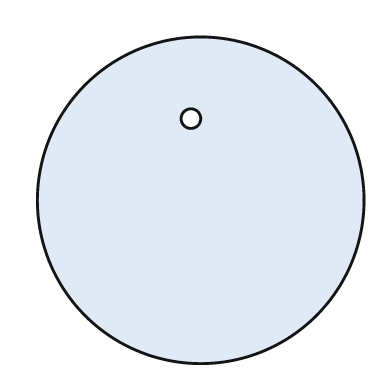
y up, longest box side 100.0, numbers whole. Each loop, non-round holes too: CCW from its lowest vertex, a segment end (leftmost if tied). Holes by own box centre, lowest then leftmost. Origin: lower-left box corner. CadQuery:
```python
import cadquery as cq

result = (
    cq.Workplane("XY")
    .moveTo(50.0, 50.0)
    .circle(50.0)
    .moveTo(47.0, 75.0)
    .circle(3.0)
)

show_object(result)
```